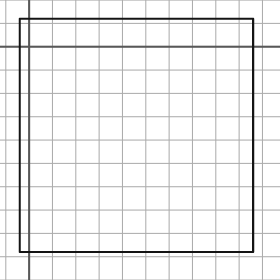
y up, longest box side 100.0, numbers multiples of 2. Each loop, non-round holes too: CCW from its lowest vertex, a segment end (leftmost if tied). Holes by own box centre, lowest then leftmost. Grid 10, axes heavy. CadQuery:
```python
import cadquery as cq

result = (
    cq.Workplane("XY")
    .moveTo(-4.0, -88.0)
    .lineTo(96.0, -88.0)
    .lineTo(96.0, 12.0)
    .lineTo(-4.0, 12.0)
    .close()
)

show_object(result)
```